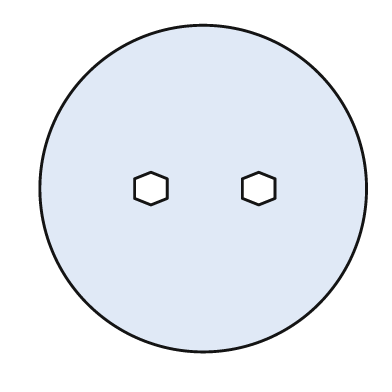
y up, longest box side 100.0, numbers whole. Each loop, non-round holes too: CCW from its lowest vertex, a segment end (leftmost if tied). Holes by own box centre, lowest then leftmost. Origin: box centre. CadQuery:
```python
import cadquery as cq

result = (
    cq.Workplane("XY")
    .moveTo(0.0, 0.0)
    .circle(50.0)
    .moveTo(-16.0, -5.0)
    .lineTo(-11.0, -3.0)
    .lineTo(-11.0, 3.0)
    .lineTo(-16.0, 5.0)
    .lineTo(-21.0, 3.0)
    .lineTo(-21.0, -3.0)
    .close()
    .moveTo(17.0, -5.0)
    .lineTo(22.0, -3.0)
    .lineTo(22.0, 3.0)
    .lineTo(17.0, 5.0)
    .lineTo(12.0, 3.0)
    .lineTo(12.0, -3.0)
    .close()
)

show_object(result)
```